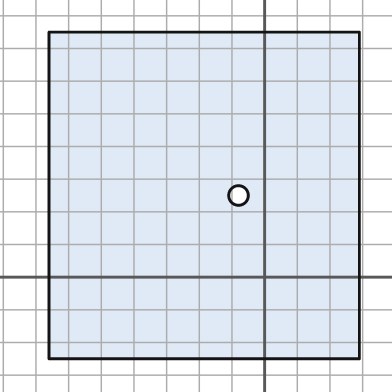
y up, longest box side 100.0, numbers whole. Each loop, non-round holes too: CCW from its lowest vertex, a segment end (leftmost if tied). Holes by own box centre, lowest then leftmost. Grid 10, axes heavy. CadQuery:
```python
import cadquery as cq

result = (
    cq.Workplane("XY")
    .moveTo(-66.0, -25.0)
    .lineTo(29.0, -25.0)
    .lineTo(29.0, 75.0)
    .lineTo(-66.0, 75.0)
    .close()
    .moveTo(-8.0, 25.0)
    .circle(3.0)
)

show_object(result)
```